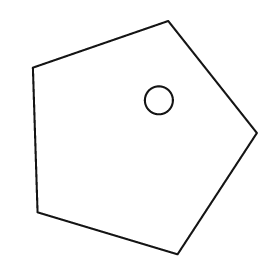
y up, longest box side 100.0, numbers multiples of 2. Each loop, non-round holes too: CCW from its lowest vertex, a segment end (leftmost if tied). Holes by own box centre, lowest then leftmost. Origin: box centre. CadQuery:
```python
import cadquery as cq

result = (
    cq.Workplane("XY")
    .moveTo(14.0, -50.0)
    .lineTo(48.0, 2.0)
    .lineTo(10.0, 50.0)
    .lineTo(-48.0, 30.0)
    .lineTo(-46.0, -32.0)
    .close()
    .moveTo(6.0, 16.0)
    .circle(6.0)
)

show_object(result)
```